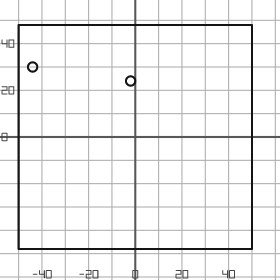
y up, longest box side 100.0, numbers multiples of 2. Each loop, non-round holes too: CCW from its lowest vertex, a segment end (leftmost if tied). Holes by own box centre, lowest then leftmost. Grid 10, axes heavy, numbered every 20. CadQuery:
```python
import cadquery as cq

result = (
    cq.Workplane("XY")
    .moveTo(-50.0, -48.0)
    .lineTo(50.0, -48.0)
    .lineTo(50.0, 48.0)
    .lineTo(-50.0, 48.0)
    .close()
    .moveTo(-2.0, 24.0)
    .circle(2.0)
    .moveTo(-44.0, 30.0)
    .circle(2.0)
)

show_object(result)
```